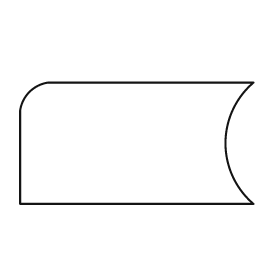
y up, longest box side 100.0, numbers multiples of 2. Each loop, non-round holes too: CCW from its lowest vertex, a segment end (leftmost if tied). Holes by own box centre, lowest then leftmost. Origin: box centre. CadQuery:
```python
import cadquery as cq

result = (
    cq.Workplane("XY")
    .moveTo(-50.0, -26.0)
    .lineTo(50.0, -26.0)
    .threePointArc((38.0, 0.0), (50.0, 26.0))
    .lineTo(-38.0, 26.0)
    .threePointArc((-46.0, 22.0), (-50.0, 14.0))
    .close()
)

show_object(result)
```